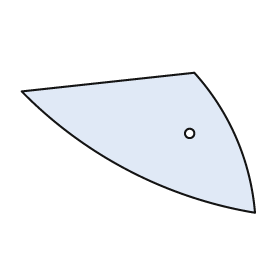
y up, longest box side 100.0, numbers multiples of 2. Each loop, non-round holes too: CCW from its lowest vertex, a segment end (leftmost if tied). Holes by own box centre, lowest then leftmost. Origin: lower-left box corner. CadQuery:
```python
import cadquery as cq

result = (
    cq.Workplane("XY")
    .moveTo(100.0, 0.0)
    .threePointArc((92.0, 32.0), (74.0, 60.0))
    .lineTo(0.0, 52.0)
    .threePointArc((46.0, 18.0), (100.0, 0.0))
    .close()
    .moveTo(72.0, 34.0)
    .circle(2.0)
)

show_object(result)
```